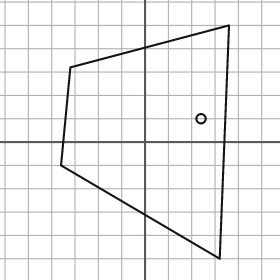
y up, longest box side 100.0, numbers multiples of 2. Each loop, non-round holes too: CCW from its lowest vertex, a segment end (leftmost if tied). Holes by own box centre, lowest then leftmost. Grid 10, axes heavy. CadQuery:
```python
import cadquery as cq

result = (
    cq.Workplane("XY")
    .moveTo(32.0, -50.0)
    .lineTo(36.0, 50.0)
    .lineTo(-32.0, 32.0)
    .lineTo(-36.0, -10.0)
    .close()
    .moveTo(24.0, 10.0)
    .circle(2.0)
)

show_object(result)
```